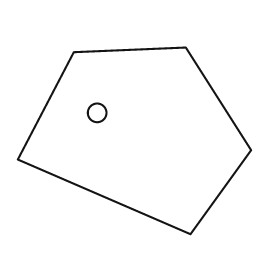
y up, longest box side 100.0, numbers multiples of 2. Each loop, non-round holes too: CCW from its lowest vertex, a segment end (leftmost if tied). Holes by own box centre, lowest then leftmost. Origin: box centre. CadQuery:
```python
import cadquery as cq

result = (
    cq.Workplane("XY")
    .moveTo(24.0, -40.0)
    .lineTo(50.0, -4.0)
    .lineTo(22.0, 40.0)
    .lineTo(-26.0, 38.0)
    .lineTo(-50.0, -8.0)
    .close()
    .moveTo(-16.0, 12.0)
    .circle(4.0)
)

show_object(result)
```